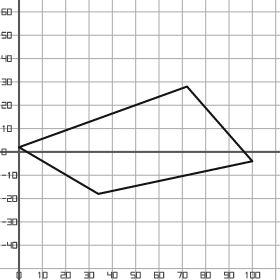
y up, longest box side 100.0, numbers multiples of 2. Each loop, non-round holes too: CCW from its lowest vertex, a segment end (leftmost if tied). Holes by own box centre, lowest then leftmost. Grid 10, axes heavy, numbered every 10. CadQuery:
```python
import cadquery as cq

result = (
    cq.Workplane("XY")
    .moveTo(34.0, -18.0)
    .lineTo(100.0, -4.0)
    .lineTo(72.0, 28.0)
    .lineTo(0.0, 2.0)
    .close()
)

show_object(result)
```